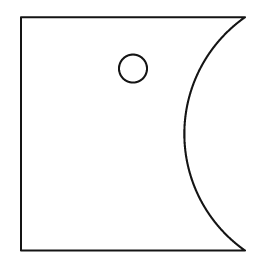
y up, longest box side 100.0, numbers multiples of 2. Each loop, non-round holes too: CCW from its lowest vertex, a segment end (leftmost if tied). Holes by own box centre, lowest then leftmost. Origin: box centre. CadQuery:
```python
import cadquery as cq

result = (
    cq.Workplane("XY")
    .moveTo(-48.0, -50.0)
    .lineTo(48.0, -50.0)
    .threePointArc((22.0, 0.0), (48.0, 50.0))
    .lineTo(-48.0, 50.0)
    .close()
    .moveTo(0.0, 28.0)
    .circle(6.0)
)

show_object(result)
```